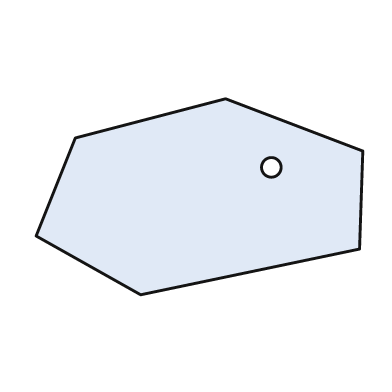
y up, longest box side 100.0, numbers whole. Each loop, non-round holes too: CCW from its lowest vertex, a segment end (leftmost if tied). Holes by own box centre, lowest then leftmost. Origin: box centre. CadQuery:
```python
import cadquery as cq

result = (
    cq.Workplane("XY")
    .moveTo(-18.0, -30.0)
    .lineTo(49.0, -16.0)
    .lineTo(50.0, 14.0)
    .lineTo(8.0, 30.0)
    .lineTo(-38.0, 18.0)
    .lineTo(-50.0, -12.0)
    .close()
    .moveTo(22.0, 9.0)
    .circle(3.0)
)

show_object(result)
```